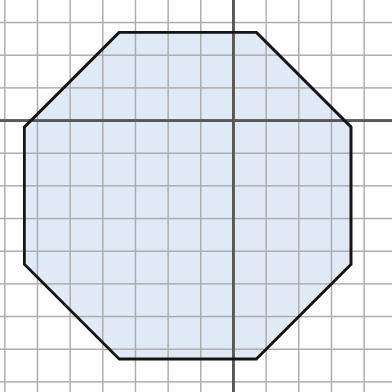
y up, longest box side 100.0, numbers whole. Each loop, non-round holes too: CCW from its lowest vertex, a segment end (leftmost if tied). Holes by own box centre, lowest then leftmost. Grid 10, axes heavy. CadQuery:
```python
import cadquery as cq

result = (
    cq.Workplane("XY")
    .moveTo(-35.0, -73.0)
    .lineTo(7.0, -73.0)
    .lineTo(36.0, -44.0)
    .lineTo(36.0, -2.0)
    .lineTo(7.0, 27.0)
    .lineTo(-35.0, 27.0)
    .lineTo(-64.0, -2.0)
    .lineTo(-64.0, -44.0)
    .close()
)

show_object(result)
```